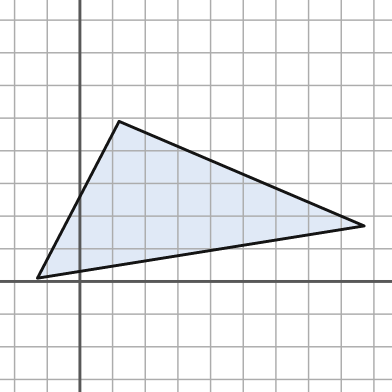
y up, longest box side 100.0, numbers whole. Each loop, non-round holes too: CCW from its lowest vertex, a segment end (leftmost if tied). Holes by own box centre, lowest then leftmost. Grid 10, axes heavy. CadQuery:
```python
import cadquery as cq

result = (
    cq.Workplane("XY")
    .moveTo(-13.0, 1.0)
    .lineTo(87.0, 17.0)
    .lineTo(12.0, 49.0)
    .close()
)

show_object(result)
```